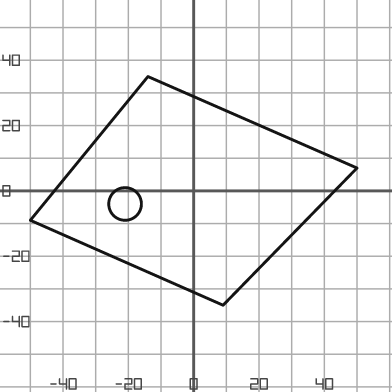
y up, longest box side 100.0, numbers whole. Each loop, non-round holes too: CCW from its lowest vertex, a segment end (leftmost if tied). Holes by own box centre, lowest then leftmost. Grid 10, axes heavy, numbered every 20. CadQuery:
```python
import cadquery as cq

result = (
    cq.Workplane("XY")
    .moveTo(9.0, -35.0)
    .lineTo(50.0, 7.0)
    .lineTo(-14.0, 35.0)
    .lineTo(-50.0, -9.0)
    .close()
    .moveTo(-21.0, -4.0)
    .circle(5.0)
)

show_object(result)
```